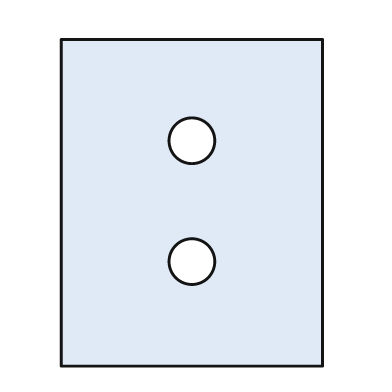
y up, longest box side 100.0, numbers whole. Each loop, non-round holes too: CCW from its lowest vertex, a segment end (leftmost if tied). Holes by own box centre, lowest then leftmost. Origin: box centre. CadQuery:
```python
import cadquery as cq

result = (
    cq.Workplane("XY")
    .moveTo(-40.0, -50.0)
    .lineTo(40.0, -50.0)
    .lineTo(40.0, 50.0)
    .lineTo(-40.0, 50.0)
    .close()
    .moveTo(0.0, -18.0)
    .circle(7.0)
    .moveTo(0.0, 19.0)
    .circle(7.0)
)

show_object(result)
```